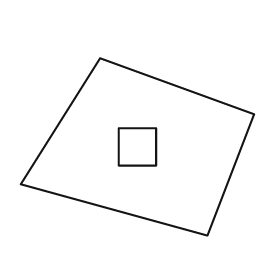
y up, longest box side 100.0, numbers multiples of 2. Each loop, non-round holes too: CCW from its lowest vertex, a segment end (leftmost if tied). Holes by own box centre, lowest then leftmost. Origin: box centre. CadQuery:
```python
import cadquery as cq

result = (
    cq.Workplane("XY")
    .moveTo(30.0, -38.0)
    .lineTo(50.0, 14.0)
    .lineTo(-16.0, 38.0)
    .lineTo(-50.0, -16.0)
    .close()
    .moveTo(-8.0, -8.0)
    .lineTo(8.0, -8.0)
    .lineTo(8.0, 8.0)
    .lineTo(-8.0, 8.0)
    .close()
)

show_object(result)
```